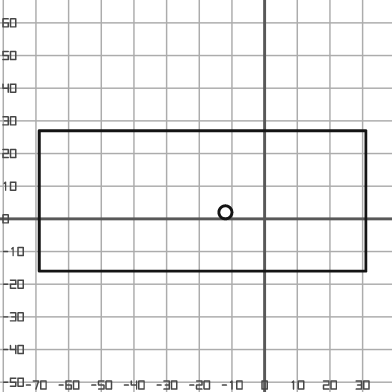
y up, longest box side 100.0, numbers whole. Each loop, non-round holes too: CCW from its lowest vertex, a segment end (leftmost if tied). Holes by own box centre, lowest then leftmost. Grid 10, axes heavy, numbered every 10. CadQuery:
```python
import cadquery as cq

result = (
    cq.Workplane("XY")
    .moveTo(-69.0, -16.0)
    .lineTo(31.0, -16.0)
    .lineTo(31.0, 27.0)
    .lineTo(-69.0, 27.0)
    .close()
    .moveTo(-12.0, 2.0)
    .circle(2.0)
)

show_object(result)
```